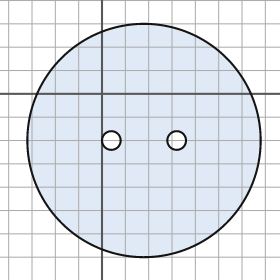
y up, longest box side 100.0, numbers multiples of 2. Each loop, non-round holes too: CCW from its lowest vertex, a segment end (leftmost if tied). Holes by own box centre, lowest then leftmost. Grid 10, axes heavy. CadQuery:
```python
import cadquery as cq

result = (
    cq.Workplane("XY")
    .moveTo(18.0, -20.0)
    .circle(50.0)
    .moveTo(4.0, -20.0)
    .circle(4.0)
    .moveTo(32.0, -20.0)
    .circle(4.0)
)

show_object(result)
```